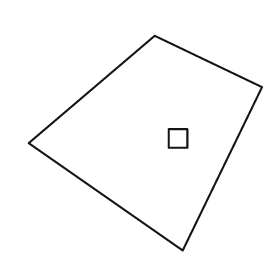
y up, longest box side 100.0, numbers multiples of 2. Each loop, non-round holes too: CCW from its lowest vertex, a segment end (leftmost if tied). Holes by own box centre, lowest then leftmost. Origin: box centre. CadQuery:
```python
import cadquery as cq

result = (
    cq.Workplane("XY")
    .moveTo(16.0, -46.0)
    .lineTo(50.0, 24.0)
    .lineTo(4.0, 46.0)
    .lineTo(-50.0, 0.0)
    .close()
    .moveTo(10.0, -2.0)
    .lineTo(18.0, -2.0)
    .lineTo(18.0, 6.0)
    .lineTo(10.0, 6.0)
    .close()
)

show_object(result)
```